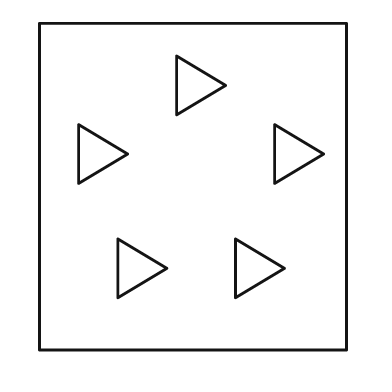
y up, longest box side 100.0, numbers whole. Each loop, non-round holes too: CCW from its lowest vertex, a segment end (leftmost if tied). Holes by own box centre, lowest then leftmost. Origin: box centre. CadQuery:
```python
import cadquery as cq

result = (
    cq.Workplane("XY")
    .moveTo(-47.0, -50.0)
    .lineTo(47.0, -50.0)
    .lineTo(47.0, 50.0)
    .lineTo(-47.0, 50.0)
    .close()
    .moveTo(-23.0, -34.0)
    .lineTo(-8.0, -25.0)
    .lineTo(-23.0, -16.0)
    .close()
    .moveTo(13.0, -34.0)
    .lineTo(28.0, -25.0)
    .lineTo(13.0, -16.0)
    .close()
    .moveTo(-35.0, 1.0)
    .lineTo(-20.0, 10.0)
    .lineTo(-35.0, 19.0)
    .close()
    .moveTo(25.0, 1.0)
    .lineTo(40.0, 10.0)
    .lineTo(25.0, 19.0)
    .close()
    .moveTo(-5.0, 22.0)
    .lineTo(10.0, 31.0)
    .lineTo(-5.0, 40.0)
    .close()
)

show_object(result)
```